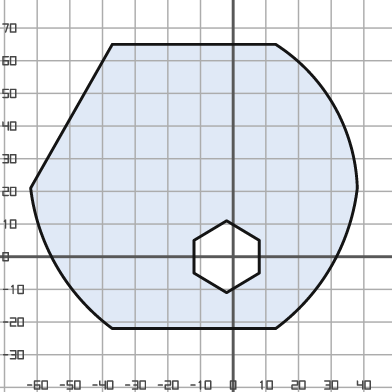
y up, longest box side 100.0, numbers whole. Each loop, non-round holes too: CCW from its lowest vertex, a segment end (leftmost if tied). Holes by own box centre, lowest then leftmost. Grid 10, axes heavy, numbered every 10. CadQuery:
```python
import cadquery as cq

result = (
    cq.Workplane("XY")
    .moveTo(-37.0, -22.0)
    .lineTo(13.0, -22.0)
    .threePointArc((30.0, -3.0), (38.0, 21.0))
    .threePointArc((31.0, 46.0), (13.0, 65.0))
    .lineTo(-37.0, 65.0)
    .lineTo(-62.0, 21.0)
    .threePointArc((-54.0, -3.0), (-37.0, -22.0))
    .close()
    .moveTo(-2.0, -11.0)
    .lineTo(8.0, -5.0)
    .lineTo(8.0, 5.0)
    .lineTo(-2.0, 11.0)
    .lineTo(-12.0, 5.0)
    .lineTo(-12.0, -5.0)
    .close()
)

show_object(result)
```